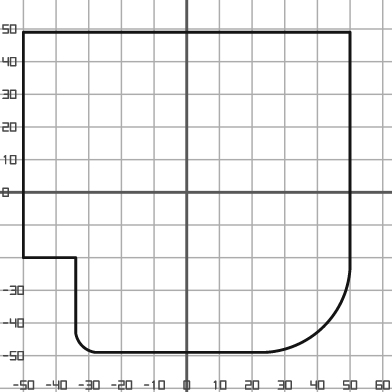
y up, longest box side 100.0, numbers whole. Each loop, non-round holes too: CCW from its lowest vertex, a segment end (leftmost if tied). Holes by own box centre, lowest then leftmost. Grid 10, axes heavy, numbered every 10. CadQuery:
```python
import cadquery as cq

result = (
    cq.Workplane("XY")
    .moveTo(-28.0, -49.0)
    .lineTo(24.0, -49.0)
    .threePointArc((42.0, -41.0), (50.0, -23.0))
    .lineTo(50.0, 49.0)
    .lineTo(-50.0, 49.0)
    .lineTo(-50.0, -20.0)
    .lineTo(-34.0, -20.0)
    .lineTo(-34.0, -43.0)
    .threePointArc((-32.0, -47.0), (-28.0, -49.0))
    .close()
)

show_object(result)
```